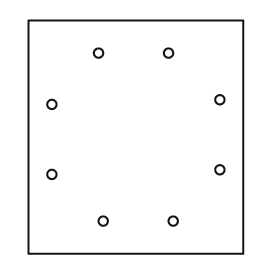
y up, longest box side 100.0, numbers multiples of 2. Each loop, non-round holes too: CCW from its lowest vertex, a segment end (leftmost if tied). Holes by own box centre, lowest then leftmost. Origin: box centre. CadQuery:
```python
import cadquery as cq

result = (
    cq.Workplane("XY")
    .moveTo(-46.0, -50.0)
    .lineTo(46.0, -50.0)
    .lineTo(46.0, 50.0)
    .lineTo(-46.0, 50.0)
    .close()
    .moveTo(-14.0, -36.0)
    .circle(2.0)
    .moveTo(16.0, -36.0)
    .circle(2.0)
    .moveTo(-36.0, -16.0)
    .circle(2.0)
    .moveTo(36.0, -14.0)
    .circle(2.0)
    .moveTo(-36.0, 14.0)
    .circle(2.0)
    .moveTo(36.0, 16.0)
    .circle(2.0)
    .moveTo(-16.0, 36.0)
    .circle(2.0)
    .moveTo(14.0, 36.0)
    .circle(2.0)
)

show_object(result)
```